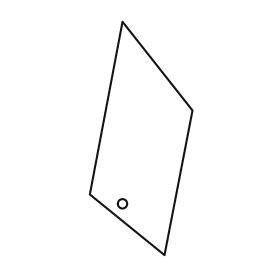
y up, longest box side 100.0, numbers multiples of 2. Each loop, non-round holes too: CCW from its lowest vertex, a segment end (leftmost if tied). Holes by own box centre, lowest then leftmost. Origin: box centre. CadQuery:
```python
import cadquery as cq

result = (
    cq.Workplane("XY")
    .moveTo(10.0, -50.0)
    .lineTo(22.0, 12.0)
    .lineTo(-8.0, 50.0)
    .lineTo(-22.0, -24.0)
    .close()
    .moveTo(-8.0, -28.0)
    .circle(2.0)
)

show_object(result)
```